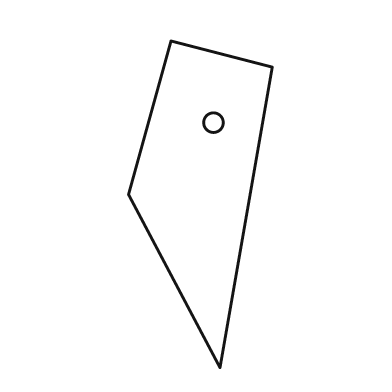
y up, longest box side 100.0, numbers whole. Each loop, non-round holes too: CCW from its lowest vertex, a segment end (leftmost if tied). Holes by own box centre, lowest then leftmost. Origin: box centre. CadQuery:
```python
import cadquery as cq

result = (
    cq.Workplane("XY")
    .moveTo(6.0, -50.0)
    .lineTo(22.0, 42.0)
    .lineTo(-9.0, 50.0)
    .lineTo(-22.0, 3.0)
    .close()
    .moveTo(4.0, 25.0)
    .circle(3.0)
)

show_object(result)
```